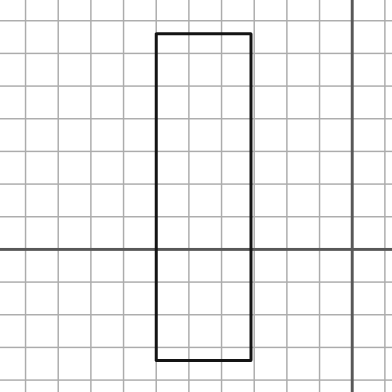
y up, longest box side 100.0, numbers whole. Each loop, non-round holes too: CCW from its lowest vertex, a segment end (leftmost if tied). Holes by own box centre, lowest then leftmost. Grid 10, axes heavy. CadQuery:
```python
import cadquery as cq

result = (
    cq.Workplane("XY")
    .moveTo(-60.0, -34.0)
    .lineTo(-31.0, -34.0)
    .lineTo(-31.0, 66.0)
    .lineTo(-60.0, 66.0)
    .close()
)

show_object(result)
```